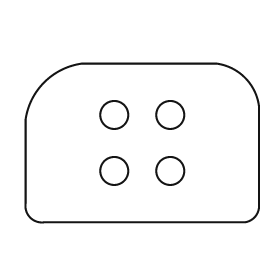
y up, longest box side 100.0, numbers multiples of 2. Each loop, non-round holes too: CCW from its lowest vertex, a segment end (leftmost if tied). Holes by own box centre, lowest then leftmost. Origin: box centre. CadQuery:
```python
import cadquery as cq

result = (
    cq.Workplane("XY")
    .moveTo(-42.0, -34.0)
    .lineTo(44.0, -34.0)
    .threePointArc((48.0, -32.0), (50.0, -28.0))
    .lineTo(50.0, 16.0)
    .threePointArc((44.0, 28.0), (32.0, 34.0))
    .lineTo(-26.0, 34.0)
    .threePointArc((-42.0, 26.0), (-50.0, 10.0))
    .lineTo(-50.0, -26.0)
    .threePointArc((-48.0, -32.0), (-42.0, -34.0))
    .close()
    .moveTo(-12.0, -12.0)
    .circle(6.0)
    .moveTo(12.0, -12.0)
    .circle(6.0)
    .moveTo(-12.0, 12.0)
    .circle(6.0)
    .moveTo(12.0, 12.0)
    .circle(6.0)
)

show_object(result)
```